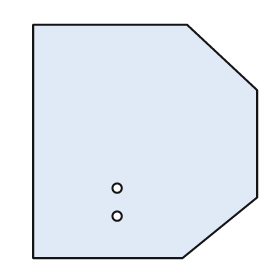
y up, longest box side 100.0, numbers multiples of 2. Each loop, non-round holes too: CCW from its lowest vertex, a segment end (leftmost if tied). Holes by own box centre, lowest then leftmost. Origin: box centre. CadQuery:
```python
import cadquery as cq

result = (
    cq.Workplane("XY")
    .moveTo(-48.0, -50.0)
    .lineTo(16.0, -50.0)
    .lineTo(48.0, -24.0)
    .lineTo(48.0, 22.0)
    .lineTo(18.0, 50.0)
    .lineTo(-48.0, 50.0)
    .close()
    .moveTo(-12.0, -32.0)
    .circle(2.0)
    .moveTo(-12.0, -20.0)
    .circle(2.0)
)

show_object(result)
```